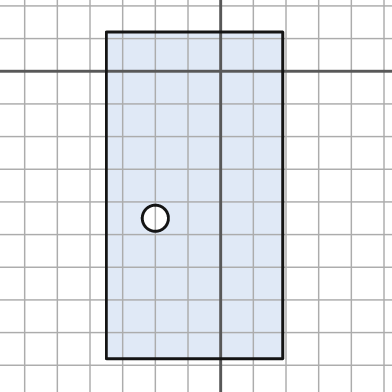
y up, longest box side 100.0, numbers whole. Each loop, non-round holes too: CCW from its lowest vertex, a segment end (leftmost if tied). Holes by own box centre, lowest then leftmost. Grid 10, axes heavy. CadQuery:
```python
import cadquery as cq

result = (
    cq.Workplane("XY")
    .moveTo(-35.0, -88.0)
    .lineTo(19.0, -88.0)
    .lineTo(19.0, 12.0)
    .lineTo(-35.0, 12.0)
    .close()
    .moveTo(-20.0, -45.0)
    .circle(4.0)
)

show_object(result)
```